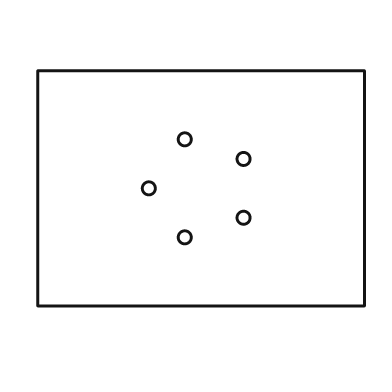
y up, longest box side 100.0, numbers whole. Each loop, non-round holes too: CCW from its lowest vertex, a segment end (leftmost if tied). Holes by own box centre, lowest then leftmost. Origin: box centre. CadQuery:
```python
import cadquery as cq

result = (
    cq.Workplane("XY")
    .moveTo(-50.0, -36.0)
    .lineTo(50.0, -36.0)
    .lineTo(50.0, 36.0)
    .lineTo(-50.0, 36.0)
    .close()
    .moveTo(-5.0, -15.0)
    .circle(2.0)
    .moveTo(13.0, -9.0)
    .circle(2.0)
    .moveTo(-16.0, 0.0)
    .circle(2.0)
    .moveTo(13.0, 9.0)
    .circle(2.0)
    .moveTo(-5.0, 15.0)
    .circle(2.0)
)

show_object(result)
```